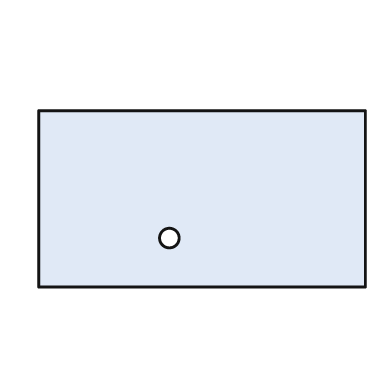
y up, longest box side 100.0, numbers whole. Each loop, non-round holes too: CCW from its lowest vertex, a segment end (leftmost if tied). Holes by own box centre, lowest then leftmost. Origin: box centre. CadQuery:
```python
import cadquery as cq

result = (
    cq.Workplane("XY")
    .moveTo(-50.0, -27.0)
    .lineTo(50.0, -27.0)
    .lineTo(50.0, 27.0)
    .lineTo(-50.0, 27.0)
    .close()
    .moveTo(-10.0, -12.0)
    .circle(3.0)
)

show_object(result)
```